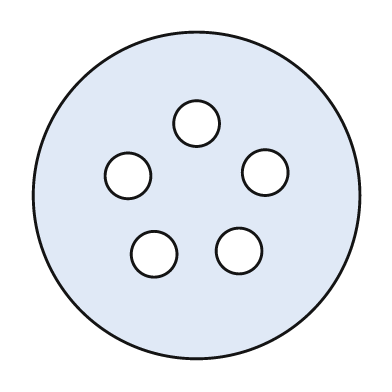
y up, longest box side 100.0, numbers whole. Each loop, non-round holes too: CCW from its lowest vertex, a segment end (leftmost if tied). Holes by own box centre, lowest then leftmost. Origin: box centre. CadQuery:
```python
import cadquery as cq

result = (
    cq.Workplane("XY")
    .moveTo(0.0, 0.0)
    .circle(50.0)
    .moveTo(-13.0, -18.0)
    .circle(7.0)
    .moveTo(13.0, -17.0)
    .circle(7.0)
    .moveTo(-21.0, 6.0)
    .circle(7.0)
    .moveTo(21.0, 7.0)
    .circle(7.0)
    .moveTo(0.0, 22.0)
    .circle(7.0)
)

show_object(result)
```